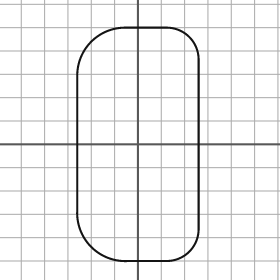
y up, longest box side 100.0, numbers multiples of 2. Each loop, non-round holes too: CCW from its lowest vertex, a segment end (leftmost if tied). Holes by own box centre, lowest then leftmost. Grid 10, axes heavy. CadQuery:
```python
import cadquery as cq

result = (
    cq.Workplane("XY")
    .moveTo(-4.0, -50.0)
    .lineTo(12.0, -50.0)
    .threePointArc((22.0, -46.0), (26.0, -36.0))
    .lineTo(26.0, 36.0)
    .threePointArc((22.0, 46.0), (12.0, 50.0))
    .lineTo(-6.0, 50.0)
    .threePointArc((-20.0, 44.0), (-26.0, 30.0))
    .lineTo(-26.0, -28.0)
    .threePointArc((-20.0, -44.0), (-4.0, -50.0))
    .close()
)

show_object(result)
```